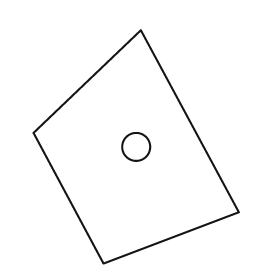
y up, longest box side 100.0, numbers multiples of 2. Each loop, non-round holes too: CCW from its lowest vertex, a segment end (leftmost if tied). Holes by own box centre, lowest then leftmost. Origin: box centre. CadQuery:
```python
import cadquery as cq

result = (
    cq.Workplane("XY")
    .moveTo(-14.0, -50.0)
    .lineTo(44.0, -28.0)
    .lineTo(2.0, 50.0)
    .lineTo(-44.0, 6.0)
    .close()
    .moveTo(0.0, 0.0)
    .circle(6.0)
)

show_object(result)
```